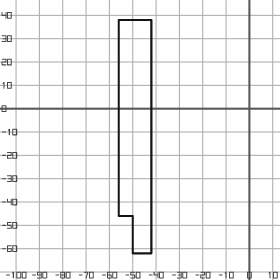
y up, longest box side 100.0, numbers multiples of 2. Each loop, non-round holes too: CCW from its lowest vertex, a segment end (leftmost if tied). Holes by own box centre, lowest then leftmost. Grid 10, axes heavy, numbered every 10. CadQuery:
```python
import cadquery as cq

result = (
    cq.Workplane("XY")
    .moveTo(-50.0, -62.0)
    .lineTo(-42.0, -62.0)
    .lineTo(-42.0, 38.0)
    .lineTo(-56.0, 38.0)
    .lineTo(-56.0, -46.0)
    .lineTo(-50.0, -46.0)
    .close()
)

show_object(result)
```